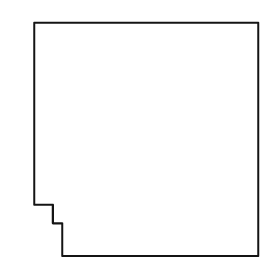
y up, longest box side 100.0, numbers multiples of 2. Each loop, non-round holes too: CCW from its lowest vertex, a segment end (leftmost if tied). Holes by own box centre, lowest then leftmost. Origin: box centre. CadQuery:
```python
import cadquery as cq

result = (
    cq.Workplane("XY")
    .moveTo(-36.0, -50.0)
    .lineTo(48.0, -50.0)
    .lineTo(48.0, 50.0)
    .lineTo(-48.0, 50.0)
    .lineTo(-48.0, -28.0)
    .lineTo(-40.0, -28.0)
    .lineTo(-40.0, -36.0)
    .lineTo(-36.0, -36.0)
    .close()
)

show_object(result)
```